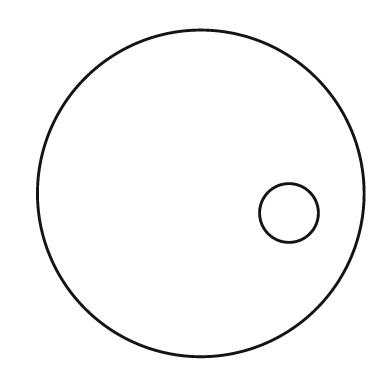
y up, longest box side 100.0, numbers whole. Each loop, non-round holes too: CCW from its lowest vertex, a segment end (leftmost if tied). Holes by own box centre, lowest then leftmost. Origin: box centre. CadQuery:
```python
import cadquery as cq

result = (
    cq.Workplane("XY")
    .moveTo(0.0, 0.0)
    .circle(50.0)
    .moveTo(27.0, -6.0)
    .circle(9.0)
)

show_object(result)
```